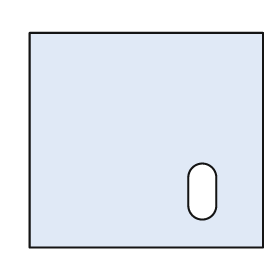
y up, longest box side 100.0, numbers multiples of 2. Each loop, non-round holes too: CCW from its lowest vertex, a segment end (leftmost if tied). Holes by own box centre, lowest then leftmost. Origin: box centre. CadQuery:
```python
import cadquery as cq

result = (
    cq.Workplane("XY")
    .moveTo(-50.0, -46.0)
    .lineTo(50.0, -46.0)
    .lineTo(50.0, 46.0)
    .lineTo(-50.0, 46.0)
    .close()
    .moveTo(18.0, -28.0)
    .threePointArc((24.0, -34.0), (30.0, -28.0))
    .lineTo(30.0, -16.0)
    .threePointArc((24.0, -10.0), (18.0, -16.0))
    .close()
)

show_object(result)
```